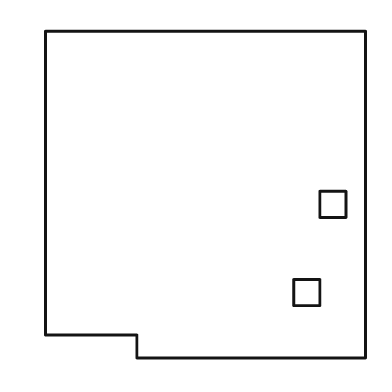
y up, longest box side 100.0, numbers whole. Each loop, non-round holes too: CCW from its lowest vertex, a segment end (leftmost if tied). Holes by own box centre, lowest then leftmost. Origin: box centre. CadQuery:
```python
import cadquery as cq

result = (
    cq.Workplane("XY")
    .moveTo(-21.0, -50.0)
    .lineTo(49.0, -50.0)
    .lineTo(49.0, 50.0)
    .lineTo(-49.0, 50.0)
    .lineTo(-49.0, -43.0)
    .lineTo(-21.0, -43.0)
    .close()
    .moveTo(27.0, -34.0)
    .lineTo(35.0, -34.0)
    .lineTo(35.0, -26.0)
    .lineTo(27.0, -26.0)
    .close()
    .moveTo(35.0, -7.0)
    .lineTo(43.0, -7.0)
    .lineTo(43.0, 1.0)
    .lineTo(35.0, 1.0)
    .close()
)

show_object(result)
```